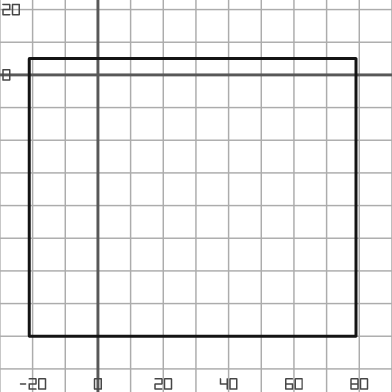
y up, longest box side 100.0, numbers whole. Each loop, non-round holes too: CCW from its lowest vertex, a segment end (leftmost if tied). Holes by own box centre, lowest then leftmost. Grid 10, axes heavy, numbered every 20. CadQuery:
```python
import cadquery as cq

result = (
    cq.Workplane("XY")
    .moveTo(-21.0, -80.0)
    .lineTo(79.0, -80.0)
    .lineTo(79.0, 5.0)
    .lineTo(-21.0, 5.0)
    .close()
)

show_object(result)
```